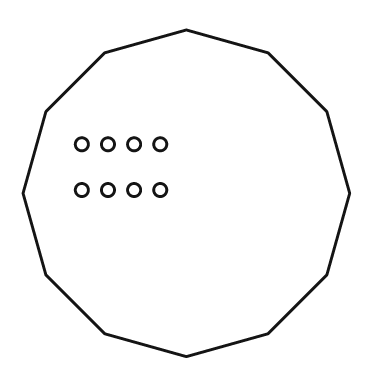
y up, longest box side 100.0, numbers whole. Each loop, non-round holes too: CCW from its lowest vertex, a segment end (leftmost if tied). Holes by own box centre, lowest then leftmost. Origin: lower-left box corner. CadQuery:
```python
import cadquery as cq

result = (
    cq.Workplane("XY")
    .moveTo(50.0, 0.0)
    .lineTo(75.0, 7.0)
    .lineTo(93.0, 25.0)
    .lineTo(100.0, 50.0)
    .lineTo(93.0, 75.0)
    .lineTo(75.0, 93.0)
    .lineTo(50.0, 100.0)
    .lineTo(25.0, 93.0)
    .lineTo(7.0, 75.0)
    .lineTo(0.0, 50.0)
    .lineTo(7.0, 25.0)
    .lineTo(25.0, 7.0)
    .close()
    .moveTo(18.0, 51.0)
    .circle(2.0)
    .moveTo(26.0, 51.0)
    .circle(2.0)
    .moveTo(34.0, 51.0)
    .circle(2.0)
    .moveTo(42.0, 51.0)
    .circle(2.0)
    .moveTo(18.0, 65.0)
    .circle(2.0)
    .moveTo(26.0, 65.0)
    .circle(2.0)
    .moveTo(34.0, 65.0)
    .circle(2.0)
    .moveTo(42.0, 65.0)
    .circle(2.0)
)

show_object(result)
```